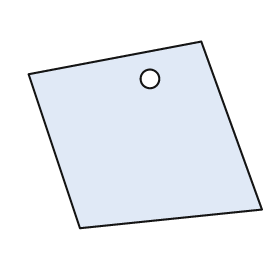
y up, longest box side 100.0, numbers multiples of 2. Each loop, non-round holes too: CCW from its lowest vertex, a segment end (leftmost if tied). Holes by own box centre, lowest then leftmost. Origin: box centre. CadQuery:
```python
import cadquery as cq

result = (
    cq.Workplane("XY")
    .moveTo(-28.0, -40.0)
    .lineTo(50.0, -32.0)
    .lineTo(24.0, 40.0)
    .lineTo(-50.0, 26.0)
    .close()
    .moveTo(2.0, 24.0)
    .circle(4.0)
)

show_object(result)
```